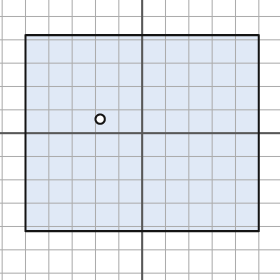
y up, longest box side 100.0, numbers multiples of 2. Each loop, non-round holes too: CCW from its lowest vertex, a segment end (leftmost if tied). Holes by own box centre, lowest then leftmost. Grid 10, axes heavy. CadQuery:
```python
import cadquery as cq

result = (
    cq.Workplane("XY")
    .moveTo(-50.0, -42.0)
    .lineTo(50.0, -42.0)
    .lineTo(50.0, 42.0)
    .lineTo(-50.0, 42.0)
    .close()
    .moveTo(-18.0, 6.0)
    .circle(2.0)
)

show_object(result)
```